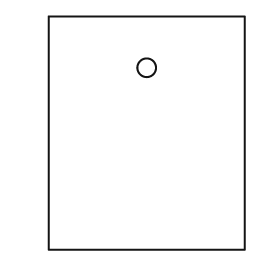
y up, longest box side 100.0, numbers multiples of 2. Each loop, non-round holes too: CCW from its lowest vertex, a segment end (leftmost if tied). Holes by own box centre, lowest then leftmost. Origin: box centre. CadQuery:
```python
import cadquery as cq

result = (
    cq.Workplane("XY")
    .moveTo(-42.0, -50.0)
    .lineTo(42.0, -50.0)
    .lineTo(42.0, 50.0)
    .lineTo(-42.0, 50.0)
    .close()
    .moveTo(0.0, 28.0)
    .circle(4.0)
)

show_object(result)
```